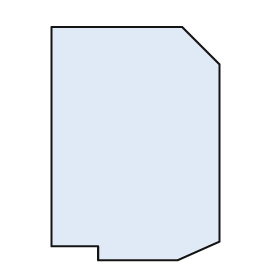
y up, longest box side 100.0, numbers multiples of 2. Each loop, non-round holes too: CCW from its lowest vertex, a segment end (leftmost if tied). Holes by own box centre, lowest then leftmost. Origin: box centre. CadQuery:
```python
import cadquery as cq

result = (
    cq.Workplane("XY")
    .moveTo(-16.0, -50.0)
    .lineTo(18.0, -50.0)
    .lineTo(36.0, -42.0)
    .lineTo(36.0, 34.0)
    .lineTo(20.0, 50.0)
    .lineTo(-36.0, 50.0)
    .lineTo(-36.0, -44.0)
    .lineTo(-16.0, -44.0)
    .close()
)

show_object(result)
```